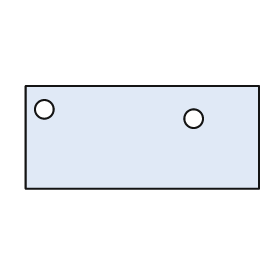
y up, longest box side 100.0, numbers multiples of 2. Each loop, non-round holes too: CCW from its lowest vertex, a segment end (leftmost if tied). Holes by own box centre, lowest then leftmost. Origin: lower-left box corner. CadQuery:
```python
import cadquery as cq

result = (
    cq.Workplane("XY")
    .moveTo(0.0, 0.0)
    .lineTo(100.0, 0.0)
    .lineTo(100.0, 44.0)
    .lineTo(0.0, 44.0)
    .close()
    .moveTo(72.0, 30.0)
    .circle(4.0)
    .moveTo(8.0, 34.0)
    .circle(4.0)
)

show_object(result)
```